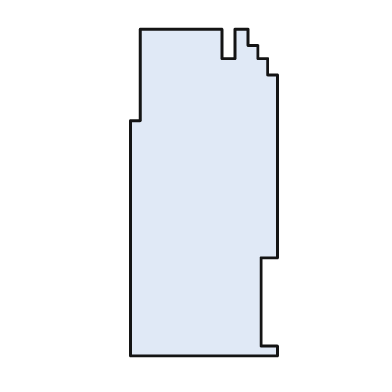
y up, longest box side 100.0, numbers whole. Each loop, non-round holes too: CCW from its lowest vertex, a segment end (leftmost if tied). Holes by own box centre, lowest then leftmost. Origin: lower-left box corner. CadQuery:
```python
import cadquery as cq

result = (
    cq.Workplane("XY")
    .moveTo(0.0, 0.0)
    .lineTo(45.0, 0.0)
    .lineTo(45.0, 3.0)
    .lineTo(40.0, 3.0)
    .lineTo(40.0, 30.0)
    .lineTo(45.0, 30.0)
    .lineTo(45.0, 86.0)
    .lineTo(42.0, 86.0)
    .lineTo(42.0, 91.0)
    .lineTo(39.0, 91.0)
    .lineTo(39.0, 95.0)
    .lineTo(36.0, 95.0)
    .lineTo(36.0, 100.0)
    .lineTo(32.0, 100.0)
    .lineTo(32.0, 91.0)
    .lineTo(28.0, 91.0)
    .lineTo(28.0, 100.0)
    .lineTo(3.0, 100.0)
    .lineTo(3.0, 72.0)
    .lineTo(0.0, 72.0)
    .close()
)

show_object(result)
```